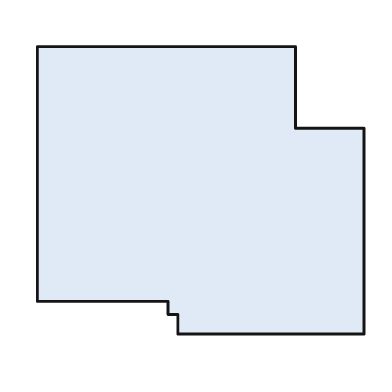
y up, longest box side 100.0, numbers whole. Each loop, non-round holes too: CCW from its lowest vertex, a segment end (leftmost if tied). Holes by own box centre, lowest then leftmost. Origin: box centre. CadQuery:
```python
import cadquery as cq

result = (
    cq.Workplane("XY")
    .moveTo(-7.0, -44.0)
    .lineTo(50.0, -44.0)
    .lineTo(50.0, 19.0)
    .lineTo(29.0, 19.0)
    .lineTo(29.0, 44.0)
    .lineTo(-50.0, 44.0)
    .lineTo(-50.0, -34.0)
    .lineTo(-10.0, -34.0)
    .lineTo(-10.0, -38.0)
    .lineTo(-7.0, -38.0)
    .close()
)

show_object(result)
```